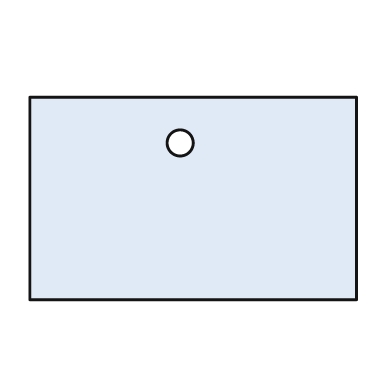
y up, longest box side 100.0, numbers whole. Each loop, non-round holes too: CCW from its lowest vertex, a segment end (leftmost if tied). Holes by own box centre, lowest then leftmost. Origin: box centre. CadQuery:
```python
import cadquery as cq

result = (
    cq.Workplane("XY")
    .moveTo(-50.0, -31.0)
    .lineTo(50.0, -31.0)
    .lineTo(50.0, 31.0)
    .lineTo(-50.0, 31.0)
    .close()
    .moveTo(-4.0, 17.0)
    .circle(4.0)
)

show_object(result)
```